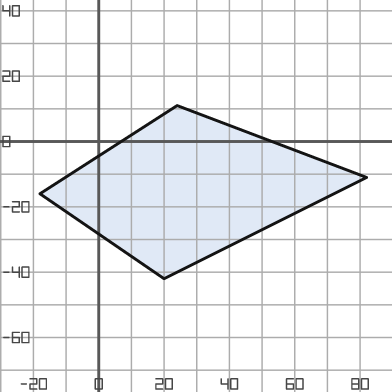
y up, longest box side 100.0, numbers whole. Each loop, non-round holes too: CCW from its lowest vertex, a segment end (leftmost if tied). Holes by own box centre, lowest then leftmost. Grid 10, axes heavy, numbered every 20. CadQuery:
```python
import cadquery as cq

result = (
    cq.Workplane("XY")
    .moveTo(20.0, -42.0)
    .lineTo(82.0, -11.0)
    .lineTo(24.0, 11.0)
    .lineTo(-18.0, -16.0)
    .close()
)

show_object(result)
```